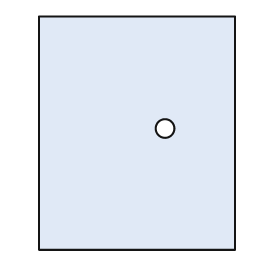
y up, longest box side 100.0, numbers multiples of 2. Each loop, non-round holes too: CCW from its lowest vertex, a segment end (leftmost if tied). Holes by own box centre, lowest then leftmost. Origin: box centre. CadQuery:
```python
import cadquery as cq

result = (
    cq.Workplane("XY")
    .moveTo(-42.0, -50.0)
    .lineTo(42.0, -50.0)
    .lineTo(42.0, 50.0)
    .lineTo(-42.0, 50.0)
    .close()
    .moveTo(12.0, 2.0)
    .circle(4.0)
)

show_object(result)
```